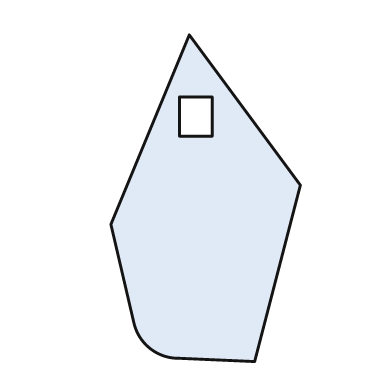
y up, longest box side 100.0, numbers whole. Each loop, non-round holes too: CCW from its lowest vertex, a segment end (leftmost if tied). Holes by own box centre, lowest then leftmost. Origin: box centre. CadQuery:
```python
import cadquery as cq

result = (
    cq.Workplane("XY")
    .moveTo(15.0, -50.0)
    .lineTo(29.0, 4.0)
    .lineTo(-5.0, 50.0)
    .lineTo(-29.0, -8.0)
    .lineTo(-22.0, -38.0)
    .threePointArc((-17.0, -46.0), (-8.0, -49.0))
    .close()
    .moveTo(-8.0, 19.0)
    .lineTo(2.0, 19.0)
    .lineTo(2.0, 31.0)
    .lineTo(-8.0, 31.0)
    .close()
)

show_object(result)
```